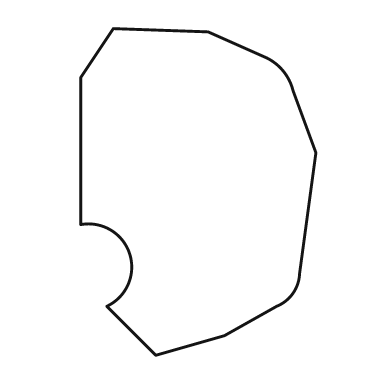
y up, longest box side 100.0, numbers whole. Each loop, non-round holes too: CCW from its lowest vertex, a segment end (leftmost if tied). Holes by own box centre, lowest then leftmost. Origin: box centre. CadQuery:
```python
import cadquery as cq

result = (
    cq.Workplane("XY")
    .moveTo(-13.0, -50.0)
    .lineTo(8.0, -44.0)
    .lineTo(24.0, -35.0)
    .threePointArc((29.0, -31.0), (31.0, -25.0))
    .lineTo(36.0, 12.0)
    .lineTo(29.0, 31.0)
    .threePointArc((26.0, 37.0), (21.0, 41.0))
    .lineTo(3.0, 49.0)
    .lineTo(-26.0, 50.0)
    .lineTo(-36.0, 35.0)
    .lineTo(-36.0, -10.0)
    .threePointArc((-21.0, -19.0), (-28.0, -35.0))
    .close()
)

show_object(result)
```